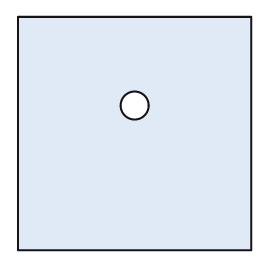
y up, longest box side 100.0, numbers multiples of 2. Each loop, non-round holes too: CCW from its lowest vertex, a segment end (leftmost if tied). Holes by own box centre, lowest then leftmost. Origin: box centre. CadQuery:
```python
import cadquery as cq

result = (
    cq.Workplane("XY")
    .moveTo(-50.0, -50.0)
    .lineTo(50.0, -50.0)
    .lineTo(50.0, 50.0)
    .lineTo(-50.0, 50.0)
    .close()
    .moveTo(0.0, 12.0)
    .circle(6.0)
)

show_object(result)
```